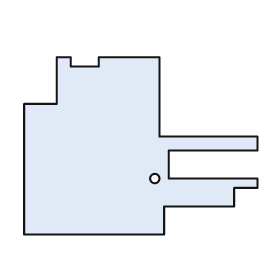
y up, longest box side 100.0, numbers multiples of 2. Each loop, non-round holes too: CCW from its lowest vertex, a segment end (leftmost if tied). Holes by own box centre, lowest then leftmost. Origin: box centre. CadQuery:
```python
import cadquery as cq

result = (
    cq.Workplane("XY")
    .moveTo(-50.0, -38.0)
    .lineTo(10.0, -38.0)
    .lineTo(10.0, -26.0)
    .lineTo(40.0, -26.0)
    .lineTo(40.0, -18.0)
    .lineTo(50.0, -18.0)
    .lineTo(50.0, -14.0)
    .lineTo(12.0, -14.0)
    .lineTo(12.0, -2.0)
    .lineTo(50.0, -2.0)
    .lineTo(50.0, 4.0)
    .lineTo(8.0, 4.0)
    .lineTo(8.0, 38.0)
    .lineTo(-18.0, 38.0)
    .lineTo(-18.0, 34.0)
    .lineTo(-30.0, 34.0)
    .lineTo(-30.0, 38.0)
    .lineTo(-36.0, 38.0)
    .lineTo(-36.0, 18.0)
    .lineTo(-50.0, 18.0)
    .close()
    .moveTo(6.0, -14.0)
    .circle(2.0)
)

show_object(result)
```